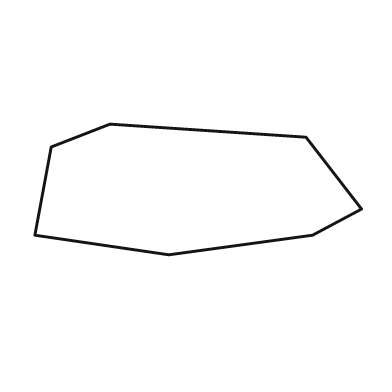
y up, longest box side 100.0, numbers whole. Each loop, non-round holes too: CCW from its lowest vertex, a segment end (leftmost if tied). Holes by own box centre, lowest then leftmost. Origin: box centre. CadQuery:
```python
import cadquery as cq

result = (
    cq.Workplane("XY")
    .moveTo(-9.0, -20.0)
    .lineTo(35.0, -14.0)
    .lineTo(50.0, -6.0)
    .lineTo(33.0, 16.0)
    .lineTo(-27.0, 20.0)
    .lineTo(-45.0, 13.0)
    .lineTo(-50.0, -14.0)
    .close()
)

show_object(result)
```